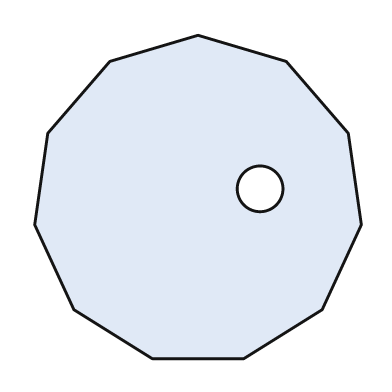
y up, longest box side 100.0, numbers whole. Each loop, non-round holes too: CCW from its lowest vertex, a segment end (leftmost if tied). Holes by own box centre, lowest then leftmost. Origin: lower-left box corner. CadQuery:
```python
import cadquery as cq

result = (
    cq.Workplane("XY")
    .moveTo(36.0, 0.0)
    .lineTo(64.0, 0.0)
    .lineTo(88.0, 15.0)
    .lineTo(100.0, 41.0)
    .lineTo(96.0, 69.0)
    .lineTo(77.0, 91.0)
    .lineTo(50.0, 99.0)
    .lineTo(23.0, 91.0)
    .lineTo(4.0, 69.0)
    .lineTo(0.0, 41.0)
    .lineTo(12.0, 15.0)
    .close()
    .moveTo(69.0, 52.0)
    .circle(7.0)
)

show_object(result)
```